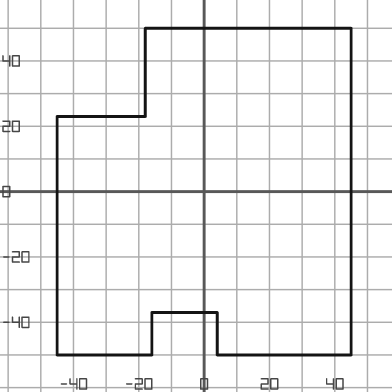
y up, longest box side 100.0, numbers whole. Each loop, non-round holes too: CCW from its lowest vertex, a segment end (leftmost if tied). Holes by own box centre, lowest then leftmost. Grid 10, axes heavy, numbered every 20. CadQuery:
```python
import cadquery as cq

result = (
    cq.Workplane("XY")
    .moveTo(-45.0, -50.0)
    .lineTo(-16.0, -50.0)
    .lineTo(-16.0, -37.0)
    .lineTo(4.0, -37.0)
    .lineTo(4.0, -50.0)
    .lineTo(45.0, -50.0)
    .lineTo(45.0, 50.0)
    .lineTo(-18.0, 50.0)
    .lineTo(-18.0, 23.0)
    .lineTo(-45.0, 23.0)
    .close()
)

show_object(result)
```